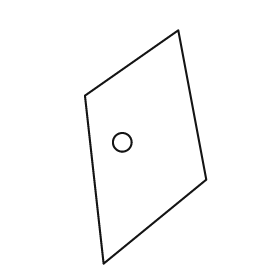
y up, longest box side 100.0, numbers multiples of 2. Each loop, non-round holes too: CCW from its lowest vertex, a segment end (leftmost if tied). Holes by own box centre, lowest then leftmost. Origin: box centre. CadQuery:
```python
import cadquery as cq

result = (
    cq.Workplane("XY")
    .moveTo(-18.0, -50.0)
    .lineTo(26.0, -14.0)
    .lineTo(14.0, 50.0)
    .lineTo(-26.0, 22.0)
    .close()
    .moveTo(-10.0, 2.0)
    .circle(4.0)
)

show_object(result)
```